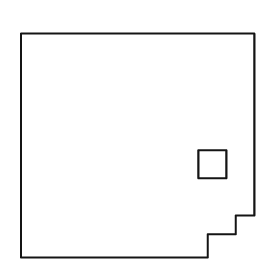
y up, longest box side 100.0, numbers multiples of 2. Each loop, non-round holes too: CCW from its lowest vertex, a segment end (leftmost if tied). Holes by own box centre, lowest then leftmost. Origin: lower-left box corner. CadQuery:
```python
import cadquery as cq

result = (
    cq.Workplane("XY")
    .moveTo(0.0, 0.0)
    .lineTo(80.0, 0.0)
    .lineTo(80.0, 10.0)
    .lineTo(92.0, 10.0)
    .lineTo(92.0, 18.0)
    .lineTo(100.0, 18.0)
    .lineTo(100.0, 96.0)
    .lineTo(0.0, 96.0)
    .close()
    .moveTo(76.0, 34.0)
    .lineTo(88.0, 34.0)
    .lineTo(88.0, 46.0)
    .lineTo(76.0, 46.0)
    .close()
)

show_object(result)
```